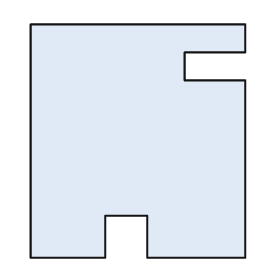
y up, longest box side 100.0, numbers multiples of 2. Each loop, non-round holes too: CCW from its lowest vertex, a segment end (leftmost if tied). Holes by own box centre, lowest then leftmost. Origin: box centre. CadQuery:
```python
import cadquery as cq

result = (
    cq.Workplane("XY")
    .moveTo(-46.0, -50.0)
    .lineTo(-14.0, -50.0)
    .lineTo(-14.0, -32.0)
    .lineTo(4.0, -32.0)
    .lineTo(4.0, -50.0)
    .lineTo(46.0, -50.0)
    .lineTo(46.0, 26.0)
    .lineTo(20.0, 26.0)
    .lineTo(20.0, 38.0)
    .lineTo(46.0, 38.0)
    .lineTo(46.0, 50.0)
    .lineTo(-46.0, 50.0)
    .close()
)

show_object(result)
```